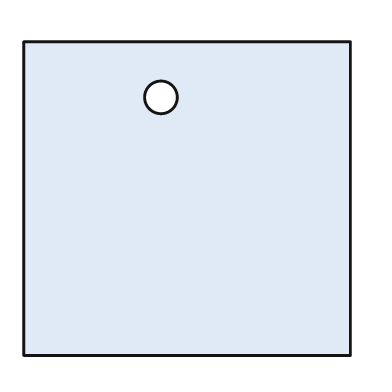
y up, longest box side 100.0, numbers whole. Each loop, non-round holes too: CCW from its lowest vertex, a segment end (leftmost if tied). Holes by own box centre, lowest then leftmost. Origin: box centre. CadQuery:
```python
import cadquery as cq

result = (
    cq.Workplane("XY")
    .moveTo(-50.0, -48.0)
    .lineTo(50.0, -48.0)
    .lineTo(50.0, 48.0)
    .lineTo(-50.0, 48.0)
    .close()
    .moveTo(-8.0, 31.0)
    .circle(5.0)
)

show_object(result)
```